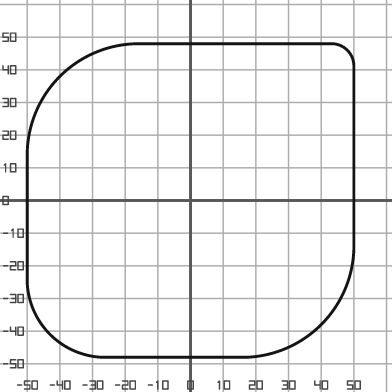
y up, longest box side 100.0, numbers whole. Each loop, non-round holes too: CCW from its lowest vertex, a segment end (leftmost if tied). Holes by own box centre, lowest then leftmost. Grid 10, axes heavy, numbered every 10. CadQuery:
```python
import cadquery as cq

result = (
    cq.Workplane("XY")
    .moveTo(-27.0, -48.0)
    .lineTo(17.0, -48.0)
    .threePointArc((40.0, -38.0), (50.0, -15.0))
    .lineTo(50.0, 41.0)
    .threePointArc((48.0, 46.0), (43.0, 48.0))
    .lineTo(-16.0, 48.0)
    .threePointArc((-40.0, 38.0), (-50.0, 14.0))
    .lineTo(-50.0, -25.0)
    .threePointArc((-43.0, -41.0), (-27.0, -48.0))
    .close()
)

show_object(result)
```